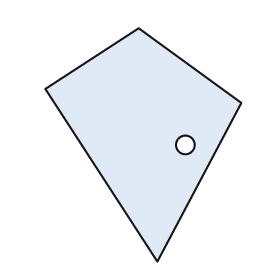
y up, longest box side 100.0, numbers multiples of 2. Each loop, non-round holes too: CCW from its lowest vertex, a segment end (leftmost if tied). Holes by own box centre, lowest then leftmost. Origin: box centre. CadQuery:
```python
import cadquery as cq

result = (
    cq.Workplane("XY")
    .moveTo(6.0, -50.0)
    .lineTo(42.0, 18.0)
    .lineTo(-2.0, 50.0)
    .lineTo(-42.0, 24.0)
    .close()
    .moveTo(18.0, 0.0)
    .circle(4.0)
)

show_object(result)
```